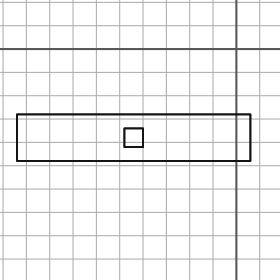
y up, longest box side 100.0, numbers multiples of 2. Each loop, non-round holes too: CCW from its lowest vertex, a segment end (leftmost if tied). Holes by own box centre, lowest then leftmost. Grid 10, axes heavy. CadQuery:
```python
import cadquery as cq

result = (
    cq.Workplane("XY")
    .moveTo(-94.0, -48.0)
    .lineTo(6.0, -48.0)
    .lineTo(6.0, -28.0)
    .lineTo(-94.0, -28.0)
    .close()
    .moveTo(-48.0, -42.0)
    .lineTo(-40.0, -42.0)
    .lineTo(-40.0, -34.0)
    .lineTo(-48.0, -34.0)
    .close()
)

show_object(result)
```